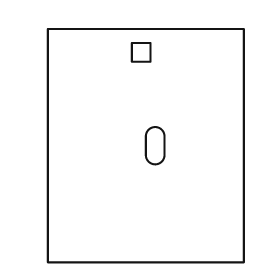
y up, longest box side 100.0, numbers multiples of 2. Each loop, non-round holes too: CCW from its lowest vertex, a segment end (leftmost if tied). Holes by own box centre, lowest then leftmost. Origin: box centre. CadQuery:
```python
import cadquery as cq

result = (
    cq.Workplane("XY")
    .moveTo(-42.0, -50.0)
    .lineTo(42.0, -50.0)
    .lineTo(42.0, 50.0)
    .lineTo(-42.0, 50.0)
    .close()
    .moveTo(0.0, -4.0)
    .threePointArc((4.0, -8.0), (8.0, -4.0))
    .lineTo(8.0, 4.0)
    .threePointArc((4.0, 8.0), (0.0, 4.0))
    .close()
    .moveTo(-6.0, 36.0)
    .lineTo(2.0, 36.0)
    .lineTo(2.0, 44.0)
    .lineTo(-6.0, 44.0)
    .close()
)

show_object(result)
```